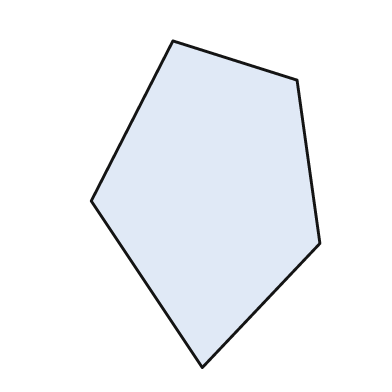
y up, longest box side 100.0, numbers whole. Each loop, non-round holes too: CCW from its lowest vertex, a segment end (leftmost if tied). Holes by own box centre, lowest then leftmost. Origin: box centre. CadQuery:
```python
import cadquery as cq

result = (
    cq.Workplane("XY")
    .moveTo(-1.0, -50.0)
    .lineTo(35.0, -12.0)
    .lineTo(28.0, 38.0)
    .lineTo(-10.0, 50.0)
    .lineTo(-35.0, 1.0)
    .close()
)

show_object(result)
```